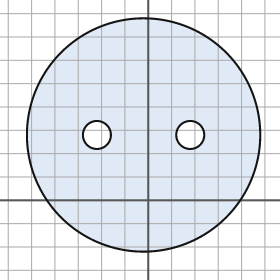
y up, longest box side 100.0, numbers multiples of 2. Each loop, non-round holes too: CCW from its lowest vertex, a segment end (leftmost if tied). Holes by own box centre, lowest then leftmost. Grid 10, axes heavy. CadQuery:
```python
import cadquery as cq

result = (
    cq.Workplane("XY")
    .moveTo(-2.0, 28.0)
    .circle(50.0)
    .moveTo(-22.0, 28.0)
    .circle(6.0)
    .moveTo(18.0, 28.0)
    .circle(6.0)
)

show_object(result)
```